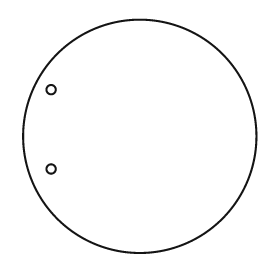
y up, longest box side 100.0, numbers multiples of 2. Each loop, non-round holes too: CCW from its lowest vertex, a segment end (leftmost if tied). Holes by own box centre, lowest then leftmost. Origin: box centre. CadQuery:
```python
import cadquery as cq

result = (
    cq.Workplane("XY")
    .moveTo(0.0, 0.0)
    .circle(50.0)
    .moveTo(-38.0, -14.0)
    .circle(2.0)
    .moveTo(-38.0, 20.0)
    .circle(2.0)
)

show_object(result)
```